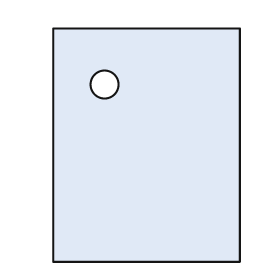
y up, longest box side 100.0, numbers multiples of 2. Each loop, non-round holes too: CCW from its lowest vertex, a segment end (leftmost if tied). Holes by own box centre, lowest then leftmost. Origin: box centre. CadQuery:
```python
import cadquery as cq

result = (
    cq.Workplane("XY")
    .moveTo(-40.0, -50.0)
    .lineTo(40.0, -50.0)
    .lineTo(40.0, 50.0)
    .lineTo(-40.0, 50.0)
    .close()
    .moveTo(-18.0, 26.0)
    .circle(6.0)
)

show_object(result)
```